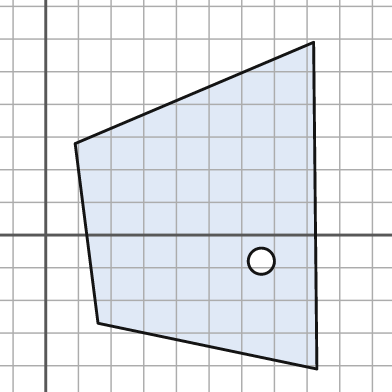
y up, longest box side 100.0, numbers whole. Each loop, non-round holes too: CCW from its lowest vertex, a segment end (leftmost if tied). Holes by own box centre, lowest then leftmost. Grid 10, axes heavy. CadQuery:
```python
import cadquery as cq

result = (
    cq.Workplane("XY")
    .moveTo(83.0, -41.0)
    .lineTo(82.0, 59.0)
    .lineTo(9.0, 28.0)
    .lineTo(16.0, -27.0)
    .close()
    .moveTo(66.0, -8.0)
    .circle(4.0)
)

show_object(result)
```